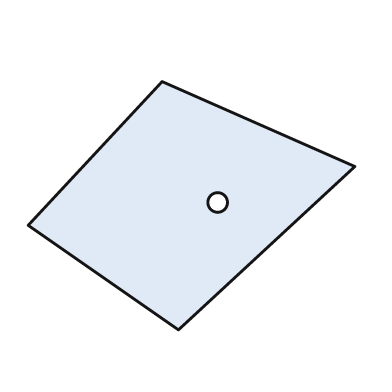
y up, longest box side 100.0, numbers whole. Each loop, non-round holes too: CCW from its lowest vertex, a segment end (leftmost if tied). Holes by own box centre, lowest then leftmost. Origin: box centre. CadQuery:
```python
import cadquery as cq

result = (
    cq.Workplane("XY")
    .moveTo(-4.0, -38.0)
    .lineTo(50.0, 12.0)
    .lineTo(-9.0, 38.0)
    .lineTo(-50.0, -6.0)
    .close()
    .moveTo(8.0, 1.0)
    .circle(3.0)
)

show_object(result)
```